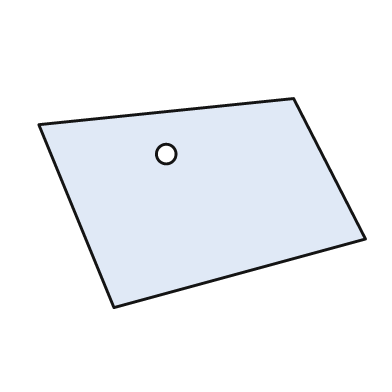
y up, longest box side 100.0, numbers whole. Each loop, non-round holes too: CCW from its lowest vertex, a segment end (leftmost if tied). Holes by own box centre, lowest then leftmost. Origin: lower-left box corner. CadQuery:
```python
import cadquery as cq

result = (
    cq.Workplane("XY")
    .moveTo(23.0, 0.0)
    .lineTo(100.0, 21.0)
    .lineTo(78.0, 64.0)
    .lineTo(0.0, 56.0)
    .close()
    .moveTo(39.0, 47.0)
    .circle(3.0)
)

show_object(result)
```